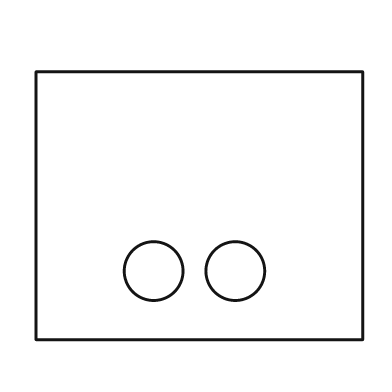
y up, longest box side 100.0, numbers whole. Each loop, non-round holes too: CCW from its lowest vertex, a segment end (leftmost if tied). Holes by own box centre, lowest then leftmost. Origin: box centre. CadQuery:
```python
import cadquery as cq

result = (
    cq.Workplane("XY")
    .moveTo(-50.0, -41.0)
    .lineTo(50.0, -41.0)
    .lineTo(50.0, 41.0)
    .lineTo(-50.0, 41.0)
    .close()
    .moveTo(-14.0, -20.0)
    .circle(9.0)
    .moveTo(11.0, -20.0)
    .circle(9.0)
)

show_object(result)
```